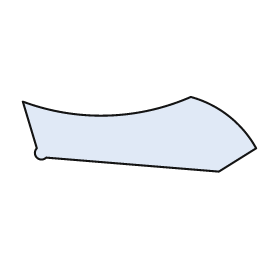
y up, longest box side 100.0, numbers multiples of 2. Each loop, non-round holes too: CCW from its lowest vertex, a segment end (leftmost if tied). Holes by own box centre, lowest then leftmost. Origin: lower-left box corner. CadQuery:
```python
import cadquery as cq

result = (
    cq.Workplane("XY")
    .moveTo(84.0, 0.0)
    .lineTo(100.0, 10.0)
    .threePointArc((88.0, 24.0), (72.0, 32.0))
    .threePointArc((36.0, 24.0), (0.0, 30.0))
    .lineTo(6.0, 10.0)
    .threePointArc((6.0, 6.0), (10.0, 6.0))
    .close()
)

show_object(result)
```